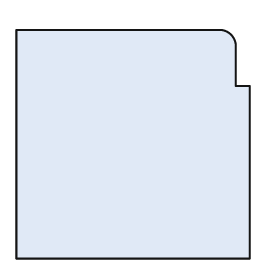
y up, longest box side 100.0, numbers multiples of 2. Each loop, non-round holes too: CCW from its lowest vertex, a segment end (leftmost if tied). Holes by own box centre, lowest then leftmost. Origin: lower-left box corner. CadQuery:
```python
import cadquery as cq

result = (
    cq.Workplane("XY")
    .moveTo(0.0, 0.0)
    .lineTo(100.0, 0.0)
    .lineTo(100.0, 74.0)
    .lineTo(94.0, 74.0)
    .lineTo(94.0, 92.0)
    .threePointArc((92.0, 96.0), (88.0, 98.0))
    .lineTo(0.0, 98.0)
    .close()
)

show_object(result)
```